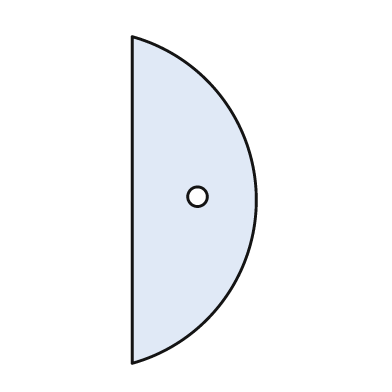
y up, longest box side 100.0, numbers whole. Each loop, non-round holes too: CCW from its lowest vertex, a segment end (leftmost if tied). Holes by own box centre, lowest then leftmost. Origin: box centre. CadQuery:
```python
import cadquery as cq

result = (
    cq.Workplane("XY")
    .moveTo(-19.0, -50.0)
    .threePointArc((19.0, 0.0), (-19.0, 50.0))
    .close()
    .moveTo(1.0, 1.0)
    .circle(3.0)
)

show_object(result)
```